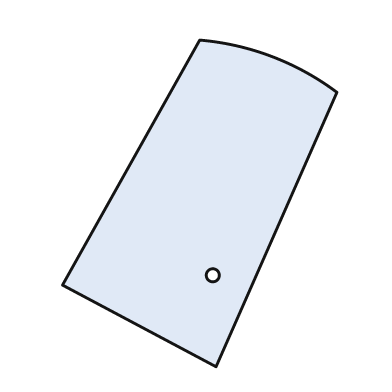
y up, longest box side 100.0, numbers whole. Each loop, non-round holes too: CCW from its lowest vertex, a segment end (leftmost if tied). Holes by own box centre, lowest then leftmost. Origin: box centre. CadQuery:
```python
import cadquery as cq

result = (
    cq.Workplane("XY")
    .moveTo(5.0, -50.0)
    .lineTo(42.0, 34.0)
    .threePointArc((22.0, 45.0), (0.0, 50.0))
    .lineTo(-42.0, -25.0)
    .close()
    .moveTo(4.0, -22.0)
    .circle(2.0)
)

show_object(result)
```